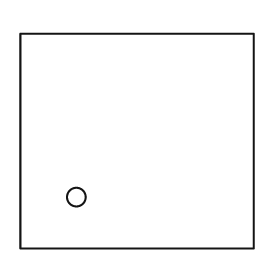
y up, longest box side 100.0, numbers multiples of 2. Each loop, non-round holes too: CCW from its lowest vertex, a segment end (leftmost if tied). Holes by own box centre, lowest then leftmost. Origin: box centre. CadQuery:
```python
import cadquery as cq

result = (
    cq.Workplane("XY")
    .moveTo(-50.0, -46.0)
    .lineTo(50.0, -46.0)
    .lineTo(50.0, 46.0)
    .lineTo(-50.0, 46.0)
    .close()
    .moveTo(-26.0, -24.0)
    .circle(4.0)
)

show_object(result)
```